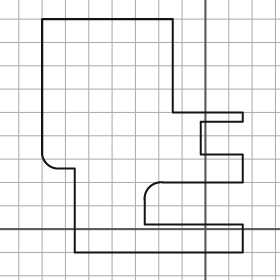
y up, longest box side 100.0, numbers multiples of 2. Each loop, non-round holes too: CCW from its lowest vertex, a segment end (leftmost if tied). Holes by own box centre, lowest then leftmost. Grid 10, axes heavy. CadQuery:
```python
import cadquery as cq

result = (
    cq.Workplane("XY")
    .moveTo(-56.0, -10.0)
    .lineTo(16.0, -10.0)
    .lineTo(16.0, 2.0)
    .lineTo(-26.0, 2.0)
    .lineTo(-26.0, 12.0)
    .threePointArc((-24.0, 18.0), (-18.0, 20.0))
    .lineTo(16.0, 20.0)
    .lineTo(16.0, 32.0)
    .lineTo(-2.0, 32.0)
    .lineTo(-2.0, 46.0)
    .lineTo(16.0, 46.0)
    .lineTo(16.0, 50.0)
    .lineTo(-14.0, 50.0)
    .lineTo(-14.0, 90.0)
    .lineTo(-70.0, 90.0)
    .lineTo(-70.0, 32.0)
    .threePointArc((-68.0, 28.0), (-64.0, 26.0))
    .lineTo(-56.0, 26.0)
    .close()
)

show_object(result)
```